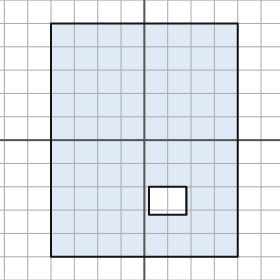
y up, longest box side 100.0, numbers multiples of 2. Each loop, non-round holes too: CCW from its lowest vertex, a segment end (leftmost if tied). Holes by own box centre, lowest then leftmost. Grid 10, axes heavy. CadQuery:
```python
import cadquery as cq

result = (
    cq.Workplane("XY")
    .moveTo(-40.0, -50.0)
    .lineTo(40.0, -50.0)
    .lineTo(40.0, 50.0)
    .lineTo(-40.0, 50.0)
    .close()
    .moveTo(2.0, -32.0)
    .lineTo(18.0, -32.0)
    .lineTo(18.0, -20.0)
    .lineTo(2.0, -20.0)
    .close()
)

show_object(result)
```